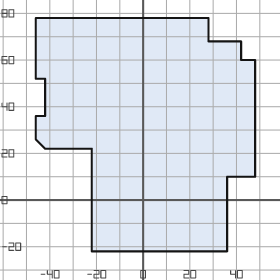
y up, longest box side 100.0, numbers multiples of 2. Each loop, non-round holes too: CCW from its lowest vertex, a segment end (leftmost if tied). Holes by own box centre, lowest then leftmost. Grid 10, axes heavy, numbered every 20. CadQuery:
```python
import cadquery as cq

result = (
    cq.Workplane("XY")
    .moveTo(-22.0, -22.0)
    .lineTo(36.0, -22.0)
    .lineTo(36.0, 10.0)
    .lineTo(48.0, 10.0)
    .lineTo(48.0, 60.0)
    .lineTo(42.0, 60.0)
    .lineTo(42.0, 68.0)
    .lineTo(28.0, 68.0)
    .lineTo(28.0, 78.0)
    .lineTo(-46.0, 78.0)
    .lineTo(-46.0, 52.0)
    .lineTo(-42.0, 52.0)
    .lineTo(-42.0, 36.0)
    .lineTo(-46.0, 36.0)
    .lineTo(-46.0, 26.0)
    .lineTo(-42.0, 22.0)
    .lineTo(-22.0, 22.0)
    .close()
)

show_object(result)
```